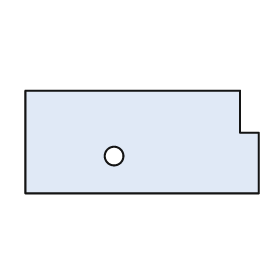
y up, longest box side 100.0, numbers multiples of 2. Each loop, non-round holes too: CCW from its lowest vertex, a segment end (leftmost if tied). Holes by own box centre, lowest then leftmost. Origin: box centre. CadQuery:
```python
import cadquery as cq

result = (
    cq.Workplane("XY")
    .moveTo(-50.0, -22.0)
    .lineTo(50.0, -22.0)
    .lineTo(50.0, 4.0)
    .lineTo(42.0, 4.0)
    .lineTo(42.0, 22.0)
    .lineTo(-50.0, 22.0)
    .close()
    .moveTo(-12.0, -6.0)
    .circle(4.0)
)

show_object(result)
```